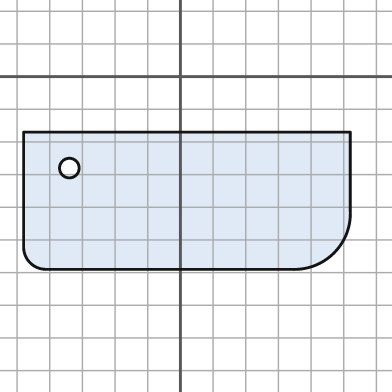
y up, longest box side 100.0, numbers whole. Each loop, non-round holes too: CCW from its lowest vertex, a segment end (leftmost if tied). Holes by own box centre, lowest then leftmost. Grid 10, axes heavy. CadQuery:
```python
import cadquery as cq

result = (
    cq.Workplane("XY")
    .moveTo(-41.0, -59.0)
    .lineTo(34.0, -59.0)
    .threePointArc((47.0, -54.0), (52.0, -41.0))
    .lineTo(52.0, -17.0)
    .lineTo(-48.0, -17.0)
    .lineTo(-48.0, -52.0)
    .threePointArc((-46.0, -57.0), (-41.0, -59.0))
    .close()
    .moveTo(-34.0, -28.0)
    .circle(3.0)
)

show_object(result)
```